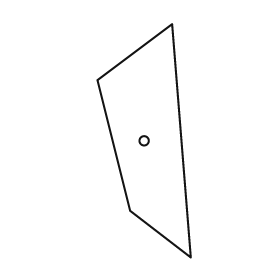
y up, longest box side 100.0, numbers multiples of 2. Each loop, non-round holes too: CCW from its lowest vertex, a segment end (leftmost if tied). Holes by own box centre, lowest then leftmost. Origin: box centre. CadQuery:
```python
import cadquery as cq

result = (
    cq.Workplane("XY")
    .moveTo(20.0, -50.0)
    .lineTo(12.0, 50.0)
    .lineTo(-20.0, 26.0)
    .lineTo(-6.0, -30.0)
    .close()
    .moveTo(0.0, 0.0)
    .circle(2.0)
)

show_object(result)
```